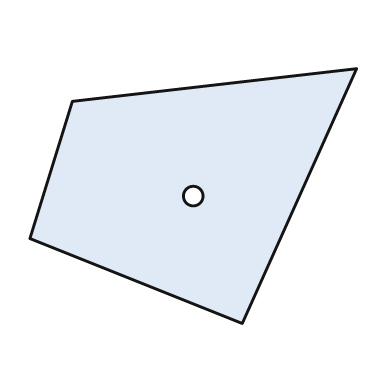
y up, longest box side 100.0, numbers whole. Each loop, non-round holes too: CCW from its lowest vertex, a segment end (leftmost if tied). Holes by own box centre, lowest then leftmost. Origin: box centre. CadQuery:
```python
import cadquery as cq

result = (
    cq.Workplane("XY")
    .moveTo(15.0, -39.0)
    .lineTo(50.0, 39.0)
    .lineTo(-37.0, 29.0)
    .lineTo(-50.0, -13.0)
    .close()
    .moveTo(0.0, 0.0)
    .circle(3.0)
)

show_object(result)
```